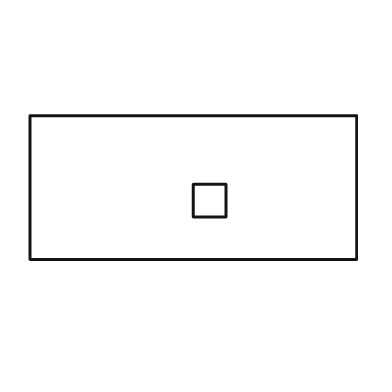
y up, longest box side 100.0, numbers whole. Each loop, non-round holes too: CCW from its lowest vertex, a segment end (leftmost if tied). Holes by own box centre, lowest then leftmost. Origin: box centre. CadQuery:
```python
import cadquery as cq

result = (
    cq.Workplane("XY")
    .moveTo(-50.0, -22.0)
    .lineTo(50.0, -22.0)
    .lineTo(50.0, 22.0)
    .lineTo(-50.0, 22.0)
    .close()
    .moveTo(0.0, -9.0)
    .lineTo(10.0, -9.0)
    .lineTo(10.0, 1.0)
    .lineTo(0.0, 1.0)
    .close()
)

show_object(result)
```